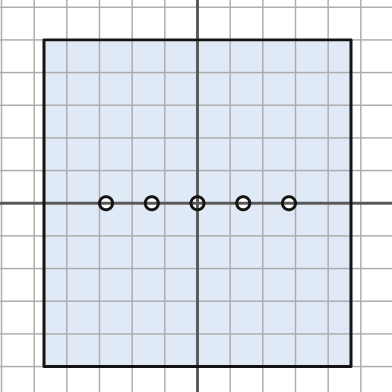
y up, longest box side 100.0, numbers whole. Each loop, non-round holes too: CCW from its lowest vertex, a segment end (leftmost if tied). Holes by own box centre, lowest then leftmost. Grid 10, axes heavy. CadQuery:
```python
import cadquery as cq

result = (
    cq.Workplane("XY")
    .moveTo(-47.0, -50.0)
    .lineTo(47.0, -50.0)
    .lineTo(47.0, 50.0)
    .lineTo(-47.0, 50.0)
    .close()
    .moveTo(-28.0, 0.0)
    .circle(2.0)
    .moveTo(-14.0, 0.0)
    .circle(2.0)
    .moveTo(0.0, 0.0)
    .circle(2.0)
    .moveTo(14.0, 0.0)
    .circle(2.0)
    .moveTo(28.0, 0.0)
    .circle(2.0)
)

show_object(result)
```